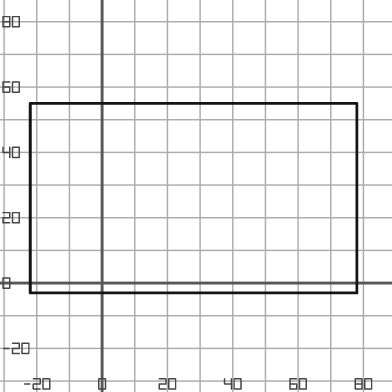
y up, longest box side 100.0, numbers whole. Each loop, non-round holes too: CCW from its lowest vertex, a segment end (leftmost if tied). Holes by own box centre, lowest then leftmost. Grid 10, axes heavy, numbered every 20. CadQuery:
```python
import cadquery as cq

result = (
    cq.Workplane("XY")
    .moveTo(-22.0, -3.0)
    .lineTo(78.0, -3.0)
    .lineTo(78.0, 55.0)
    .lineTo(-22.0, 55.0)
    .close()
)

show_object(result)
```